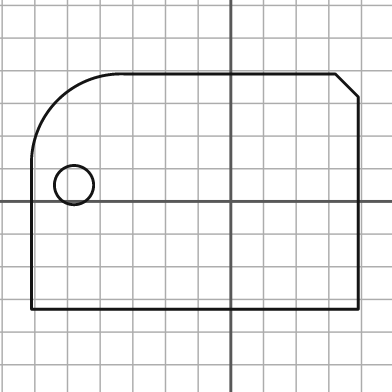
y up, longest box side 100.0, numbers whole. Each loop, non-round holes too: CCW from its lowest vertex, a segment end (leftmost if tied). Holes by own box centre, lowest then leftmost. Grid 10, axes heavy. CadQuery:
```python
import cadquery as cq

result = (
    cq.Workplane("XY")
    .moveTo(-61.0, -33.0)
    .lineTo(39.0, -33.0)
    .lineTo(39.0, 32.0)
    .lineTo(32.0, 39.0)
    .lineTo(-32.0, 39.0)
    .threePointArc((-53.0, 31.0), (-61.0, 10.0))
    .close()
    .moveTo(-48.0, 5.0)
    .circle(6.0)
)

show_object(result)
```